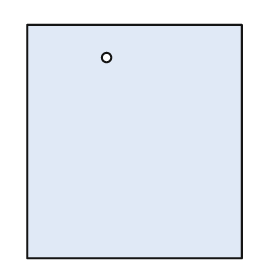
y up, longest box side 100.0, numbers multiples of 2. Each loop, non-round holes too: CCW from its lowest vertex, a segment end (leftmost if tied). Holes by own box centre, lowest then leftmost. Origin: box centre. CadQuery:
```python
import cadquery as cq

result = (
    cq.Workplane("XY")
    .moveTo(-46.0, -50.0)
    .lineTo(46.0, -50.0)
    .lineTo(46.0, 50.0)
    .lineTo(-46.0, 50.0)
    .close()
    .moveTo(-12.0, 36.0)
    .circle(2.0)
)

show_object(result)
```